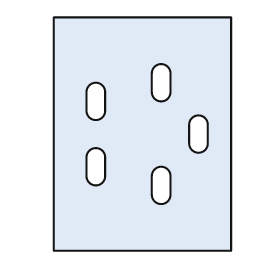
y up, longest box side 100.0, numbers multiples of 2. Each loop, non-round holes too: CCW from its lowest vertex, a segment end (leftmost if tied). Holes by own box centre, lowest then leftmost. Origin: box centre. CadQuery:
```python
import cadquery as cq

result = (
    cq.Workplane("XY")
    .moveTo(-38.0, -50.0)
    .lineTo(38.0, -50.0)
    .lineTo(38.0, 50.0)
    .lineTo(-38.0, 50.0)
    .close()
    .moveTo(4.0, -26.0)
    .threePointArc((8.0, -30.0), (12.0, -26.0))
    .lineTo(12.0, -18.0)
    .threePointArc((8.0, -14.0), (4.0, -18.0))
    .close()
    .moveTo(-24.0, -18.0)
    .threePointArc((-20.0, -22.0), (-16.0, -18.0))
    .lineTo(-16.0, -10.0)
    .threePointArc((-20.0, -6.0), (-24.0, -10.0))
    .close()
    .moveTo(20.0, -4.0)
    .threePointArc((24.0, -8.0), (28.0, -4.0))
    .lineTo(28.0, 4.0)
    .threePointArc((24.0, 8.0), (20.0, 4.0))
    .close()
    .moveTo(-24.0, 10.0)
    .threePointArc((-20.0, 6.0), (-16.0, 10.0))
    .lineTo(-16.0, 18.0)
    .threePointArc((-20.0, 22.0), (-24.0, 18.0))
    .close()
    .moveTo(4.0, 18.0)
    .threePointArc((8.0, 14.0), (12.0, 18.0))
    .lineTo(12.0, 26.0)
    .threePointArc((8.0, 30.0), (4.0, 26.0))
    .close()
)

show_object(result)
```